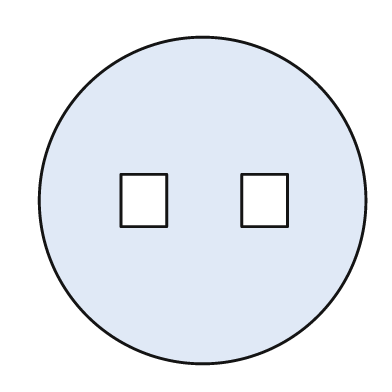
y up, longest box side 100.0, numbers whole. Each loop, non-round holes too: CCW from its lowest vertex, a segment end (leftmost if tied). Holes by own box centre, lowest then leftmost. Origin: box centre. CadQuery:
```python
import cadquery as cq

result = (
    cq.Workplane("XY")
    .moveTo(0.0, 0.0)
    .circle(50.0)
    .moveTo(-25.0, -8.0)
    .lineTo(-11.0, -8.0)
    .lineTo(-11.0, 8.0)
    .lineTo(-25.0, 8.0)
    .close()
    .moveTo(12.0, -8.0)
    .lineTo(26.0, -8.0)
    .lineTo(26.0, 8.0)
    .lineTo(12.0, 8.0)
    .close()
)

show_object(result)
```